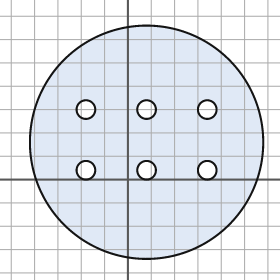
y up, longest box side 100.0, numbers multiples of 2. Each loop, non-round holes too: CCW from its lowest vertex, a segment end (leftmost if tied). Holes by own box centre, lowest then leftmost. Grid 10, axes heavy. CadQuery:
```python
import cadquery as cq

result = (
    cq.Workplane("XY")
    .moveTo(8.0, 16.0)
    .circle(50.0)
    .moveTo(-18.0, 4.0)
    .circle(4.0)
    .moveTo(8.0, 4.0)
    .circle(4.0)
    .moveTo(34.0, 4.0)
    .circle(4.0)
    .moveTo(-18.0, 30.0)
    .circle(4.0)
    .moveTo(8.0, 30.0)
    .circle(4.0)
    .moveTo(34.0, 30.0)
    .circle(4.0)
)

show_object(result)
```